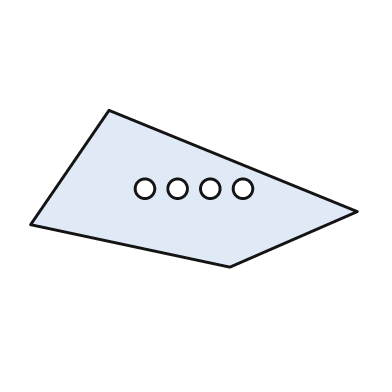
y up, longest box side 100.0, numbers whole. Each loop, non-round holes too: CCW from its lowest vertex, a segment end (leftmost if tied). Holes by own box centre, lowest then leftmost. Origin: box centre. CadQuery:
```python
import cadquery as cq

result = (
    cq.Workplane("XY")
    .moveTo(11.0, -24.0)
    .lineTo(50.0, -7.0)
    .lineTo(-26.0, 24.0)
    .lineTo(-50.0, -11.0)
    .close()
    .moveTo(-15.0, 0.0)
    .circle(3.0)
    .moveTo(-5.0, 0.0)
    .circle(3.0)
    .moveTo(5.0, 0.0)
    .circle(3.0)
    .moveTo(15.0, 0.0)
    .circle(3.0)
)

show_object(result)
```